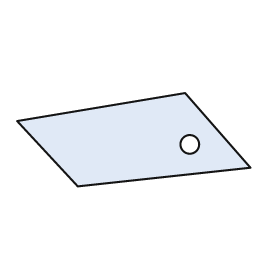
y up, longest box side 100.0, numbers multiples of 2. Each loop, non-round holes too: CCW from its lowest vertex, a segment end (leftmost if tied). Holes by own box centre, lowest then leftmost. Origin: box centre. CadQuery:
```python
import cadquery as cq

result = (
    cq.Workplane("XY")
    .moveTo(-24.0, -20.0)
    .lineTo(50.0, -12.0)
    .lineTo(22.0, 20.0)
    .lineTo(-50.0, 8.0)
    .close()
    .moveTo(24.0, -2.0)
    .circle(4.0)
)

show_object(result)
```